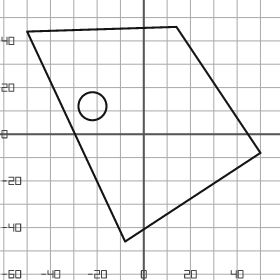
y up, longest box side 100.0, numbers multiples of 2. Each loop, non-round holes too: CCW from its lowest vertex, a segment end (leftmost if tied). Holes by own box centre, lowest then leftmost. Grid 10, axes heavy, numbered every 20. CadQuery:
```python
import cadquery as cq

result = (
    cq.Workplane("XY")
    .moveTo(-8.0, -46.0)
    .lineTo(50.0, -8.0)
    .lineTo(14.0, 46.0)
    .lineTo(-50.0, 44.0)
    .close()
    .moveTo(-22.0, 12.0)
    .circle(6.0)
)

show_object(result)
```